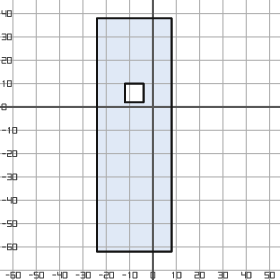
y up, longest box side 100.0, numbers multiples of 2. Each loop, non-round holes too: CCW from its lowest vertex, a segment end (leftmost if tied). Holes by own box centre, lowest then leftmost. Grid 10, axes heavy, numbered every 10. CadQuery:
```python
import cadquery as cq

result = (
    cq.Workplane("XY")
    .moveTo(-24.0, -62.0)
    .lineTo(8.0, -62.0)
    .lineTo(8.0, 38.0)
    .lineTo(-24.0, 38.0)
    .close()
    .moveTo(-12.0, 2.0)
    .lineTo(-4.0, 2.0)
    .lineTo(-4.0, 10.0)
    .lineTo(-12.0, 10.0)
    .close()
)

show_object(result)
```